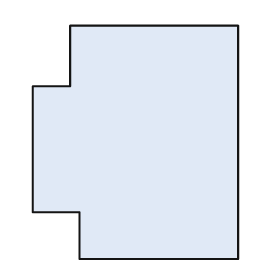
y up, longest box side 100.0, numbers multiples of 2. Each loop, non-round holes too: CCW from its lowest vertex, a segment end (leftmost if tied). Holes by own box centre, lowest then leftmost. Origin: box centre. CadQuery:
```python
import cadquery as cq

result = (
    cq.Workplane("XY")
    .moveTo(-24.0, -50.0)
    .lineTo(44.0, -50.0)
    .lineTo(44.0, 50.0)
    .lineTo(-28.0, 50.0)
    .lineTo(-28.0, 24.0)
    .lineTo(-44.0, 24.0)
    .lineTo(-44.0, -30.0)
    .lineTo(-24.0, -30.0)
    .close()
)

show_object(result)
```